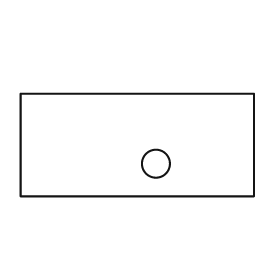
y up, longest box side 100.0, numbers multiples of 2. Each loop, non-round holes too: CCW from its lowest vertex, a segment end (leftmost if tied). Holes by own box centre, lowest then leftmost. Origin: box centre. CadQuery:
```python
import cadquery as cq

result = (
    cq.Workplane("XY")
    .moveTo(-50.0, -22.0)
    .lineTo(50.0, -22.0)
    .lineTo(50.0, 22.0)
    .lineTo(-50.0, 22.0)
    .close()
    .moveTo(8.0, -8.0)
    .circle(6.0)
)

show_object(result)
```